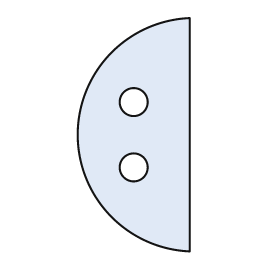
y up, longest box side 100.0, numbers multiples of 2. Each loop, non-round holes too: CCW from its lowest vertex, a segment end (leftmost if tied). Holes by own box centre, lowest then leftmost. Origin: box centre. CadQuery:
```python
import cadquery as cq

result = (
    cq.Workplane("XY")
    .moveTo(24.0, -50.0)
    .lineTo(24.0, 50.0)
    .threePointArc((-24.0, 0.0), (24.0, -50.0))
    .close()
    .moveTo(0.0, -14.0)
    .circle(6.0)
    .moveTo(0.0, 14.0)
    .circle(6.0)
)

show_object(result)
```